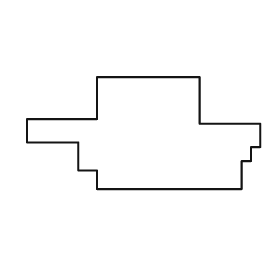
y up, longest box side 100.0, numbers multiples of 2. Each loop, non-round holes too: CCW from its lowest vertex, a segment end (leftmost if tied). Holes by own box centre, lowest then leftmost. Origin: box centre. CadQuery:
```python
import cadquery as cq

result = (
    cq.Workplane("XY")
    .moveTo(-20.0, -24.0)
    .lineTo(42.0, -24.0)
    .lineTo(42.0, -12.0)
    .lineTo(46.0, -12.0)
    .lineTo(46.0, -6.0)
    .lineTo(50.0, -6.0)
    .lineTo(50.0, 4.0)
    .lineTo(24.0, 4.0)
    .lineTo(24.0, 24.0)
    .lineTo(-20.0, 24.0)
    .lineTo(-20.0, 6.0)
    .lineTo(-50.0, 6.0)
    .lineTo(-50.0, -4.0)
    .lineTo(-28.0, -4.0)
    .lineTo(-28.0, -16.0)
    .lineTo(-20.0, -16.0)
    .close()
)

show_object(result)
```